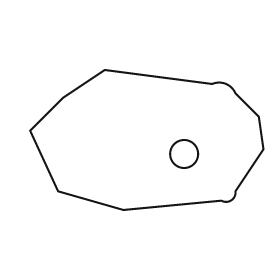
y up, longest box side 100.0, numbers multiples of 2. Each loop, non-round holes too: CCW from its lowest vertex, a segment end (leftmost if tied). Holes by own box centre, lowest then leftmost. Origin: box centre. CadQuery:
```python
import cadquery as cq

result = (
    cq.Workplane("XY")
    .moveTo(-10.0, -30.0)
    .lineTo(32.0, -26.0)
    .threePointArc((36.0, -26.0), (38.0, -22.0))
    .lineTo(50.0, -4.0)
    .lineTo(48.0, 10.0)
    .lineTo(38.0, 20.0)
    .threePointArc((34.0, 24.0), (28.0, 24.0))
    .lineTo(-18.0, 30.0)
    .lineTo(-36.0, 18.0)
    .lineTo(-50.0, 4.0)
    .lineTo(-38.0, -22.0)
    .close()
    .moveTo(16.0, -6.0)
    .circle(6.0)
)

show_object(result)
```